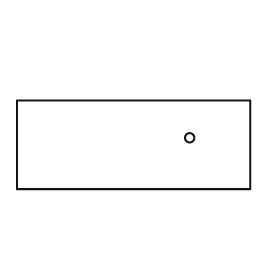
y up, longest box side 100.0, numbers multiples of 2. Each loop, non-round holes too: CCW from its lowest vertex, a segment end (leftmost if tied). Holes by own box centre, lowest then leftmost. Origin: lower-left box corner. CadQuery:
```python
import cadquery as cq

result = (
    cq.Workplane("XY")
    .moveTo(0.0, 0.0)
    .lineTo(100.0, 0.0)
    .lineTo(100.0, 38.0)
    .lineTo(0.0, 38.0)
    .close()
    .moveTo(74.0, 22.0)
    .circle(2.0)
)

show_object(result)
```